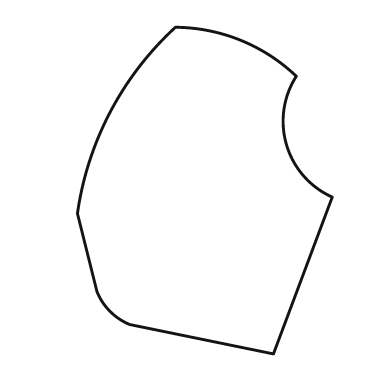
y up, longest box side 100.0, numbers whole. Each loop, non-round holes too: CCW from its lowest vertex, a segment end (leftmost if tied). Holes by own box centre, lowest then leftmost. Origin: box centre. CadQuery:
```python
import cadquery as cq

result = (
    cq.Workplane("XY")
    .moveTo(21.0, -50.0)
    .lineTo(39.0, -2.0)
    .threePointArc((25.0, 14.0), (28.0, 35.0))
    .threePointArc((11.0, 46.0), (-9.0, 50.0))
    .threePointArc((-29.0, 24.0), (-39.0, -7.0))
    .lineTo(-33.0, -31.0)
    .threePointArc((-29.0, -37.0), (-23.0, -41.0))
    .close()
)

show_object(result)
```